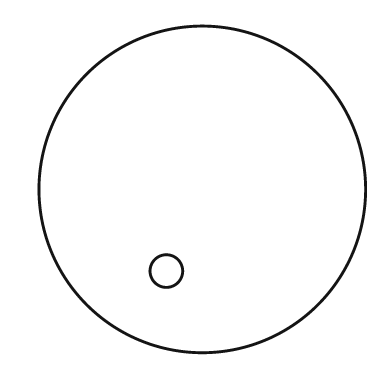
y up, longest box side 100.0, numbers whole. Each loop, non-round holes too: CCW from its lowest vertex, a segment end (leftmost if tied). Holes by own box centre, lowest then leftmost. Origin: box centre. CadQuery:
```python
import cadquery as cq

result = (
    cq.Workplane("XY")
    .moveTo(0.0, 0.0)
    .circle(50.0)
    .moveTo(-11.0, -25.0)
    .circle(5.0)
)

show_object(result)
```